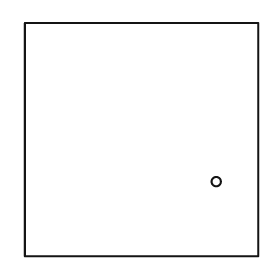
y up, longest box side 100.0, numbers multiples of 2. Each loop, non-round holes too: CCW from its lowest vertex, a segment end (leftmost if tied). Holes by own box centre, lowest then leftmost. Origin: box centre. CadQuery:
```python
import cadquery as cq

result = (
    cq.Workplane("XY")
    .moveTo(-50.0, -50.0)
    .lineTo(50.0, -50.0)
    .lineTo(50.0, 50.0)
    .lineTo(-50.0, 50.0)
    .close()
    .moveTo(32.0, -18.0)
    .circle(2.0)
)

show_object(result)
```